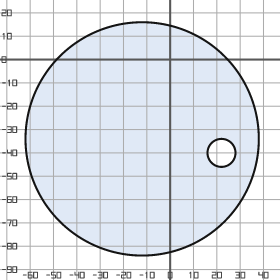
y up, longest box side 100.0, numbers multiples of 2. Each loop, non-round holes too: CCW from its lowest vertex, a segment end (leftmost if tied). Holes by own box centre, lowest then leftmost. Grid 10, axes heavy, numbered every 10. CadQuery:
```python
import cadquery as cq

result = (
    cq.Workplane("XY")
    .moveTo(-12.0, -34.0)
    .circle(50.0)
    .moveTo(22.0, -40.0)
    .circle(6.0)
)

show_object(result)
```